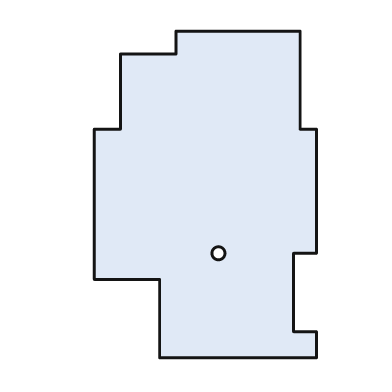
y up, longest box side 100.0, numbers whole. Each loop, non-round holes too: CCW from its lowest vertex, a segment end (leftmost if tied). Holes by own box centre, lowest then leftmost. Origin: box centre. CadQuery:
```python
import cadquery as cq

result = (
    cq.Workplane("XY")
    .moveTo(-14.0, -50.0)
    .lineTo(34.0, -50.0)
    .lineTo(34.0, -42.0)
    .lineTo(27.0, -42.0)
    .lineTo(27.0, -18.0)
    .lineTo(34.0, -18.0)
    .lineTo(34.0, 20.0)
    .lineTo(29.0, 20.0)
    .lineTo(29.0, 50.0)
    .lineTo(-9.0, 50.0)
    .lineTo(-9.0, 43.0)
    .lineTo(-26.0, 43.0)
    .lineTo(-26.0, 20.0)
    .lineTo(-34.0, 20.0)
    .lineTo(-34.0, -26.0)
    .lineTo(-14.0, -26.0)
    .close()
    .moveTo(4.0, -18.0)
    .circle(2.0)
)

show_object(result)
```